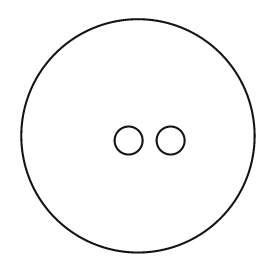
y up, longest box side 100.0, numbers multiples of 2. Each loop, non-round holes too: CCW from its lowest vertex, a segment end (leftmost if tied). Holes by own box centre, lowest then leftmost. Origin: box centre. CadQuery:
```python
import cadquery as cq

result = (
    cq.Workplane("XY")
    .moveTo(0.0, 0.0)
    .circle(50.0)
    .moveTo(-4.0, -2.0)
    .circle(6.0)
    .moveTo(14.0, -2.0)
    .circle(6.0)
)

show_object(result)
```